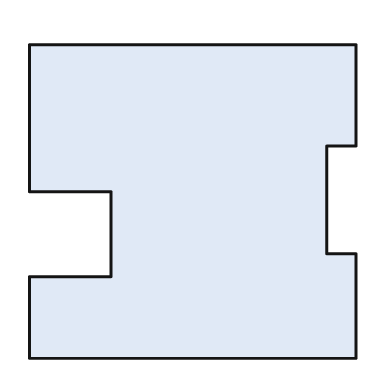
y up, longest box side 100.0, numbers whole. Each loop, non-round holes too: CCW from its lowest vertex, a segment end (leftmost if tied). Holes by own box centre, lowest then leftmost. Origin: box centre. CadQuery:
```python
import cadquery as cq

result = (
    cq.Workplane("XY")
    .moveTo(-50.0, -48.0)
    .lineTo(50.0, -48.0)
    .lineTo(50.0, -16.0)
    .lineTo(41.0, -16.0)
    .lineTo(41.0, 17.0)
    .lineTo(50.0, 17.0)
    .lineTo(50.0, 48.0)
    .lineTo(-50.0, 48.0)
    .lineTo(-50.0, 3.0)
    .lineTo(-25.0, 3.0)
    .lineTo(-25.0, -23.0)
    .lineTo(-50.0, -23.0)
    .close()
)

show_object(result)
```